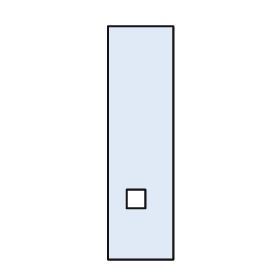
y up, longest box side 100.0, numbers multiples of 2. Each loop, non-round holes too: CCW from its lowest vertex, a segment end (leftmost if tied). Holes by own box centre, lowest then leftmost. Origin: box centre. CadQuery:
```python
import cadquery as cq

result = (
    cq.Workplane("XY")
    .moveTo(-14.0, -50.0)
    .lineTo(14.0, -50.0)
    .lineTo(14.0, 50.0)
    .lineTo(-14.0, 50.0)
    .close()
    .moveTo(-6.0, -28.0)
    .lineTo(2.0, -28.0)
    .lineTo(2.0, -20.0)
    .lineTo(-6.0, -20.0)
    .close()
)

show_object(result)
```